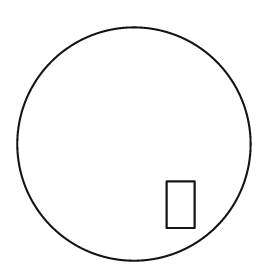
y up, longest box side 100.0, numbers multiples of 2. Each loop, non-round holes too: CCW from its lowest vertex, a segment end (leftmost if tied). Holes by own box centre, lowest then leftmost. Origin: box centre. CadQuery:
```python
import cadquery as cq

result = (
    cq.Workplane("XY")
    .moveTo(0.0, 0.0)
    .circle(50.0)
    .moveTo(14.0, -36.0)
    .lineTo(26.0, -36.0)
    .lineTo(26.0, -16.0)
    .lineTo(14.0, -16.0)
    .close()
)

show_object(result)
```